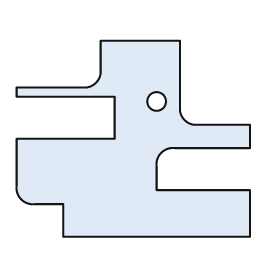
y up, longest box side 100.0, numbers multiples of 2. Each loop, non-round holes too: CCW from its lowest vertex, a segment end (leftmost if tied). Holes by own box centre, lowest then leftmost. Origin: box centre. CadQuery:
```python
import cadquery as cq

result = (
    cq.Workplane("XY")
    .moveTo(-30.0, -42.0)
    .lineTo(50.0, -42.0)
    .lineTo(50.0, -22.0)
    .lineTo(10.0, -22.0)
    .lineTo(10.0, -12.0)
    .threePointArc((12.0, -6.0), (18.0, -4.0))
    .lineTo(50.0, -4.0)
    .lineTo(50.0, 6.0)
    .lineTo(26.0, 6.0)
    .threePointArc((22.0, 8.0), (20.0, 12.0))
    .lineTo(20.0, 42.0)
    .lineTo(-14.0, 42.0)
    .lineTo(-14.0, 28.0)
    .threePointArc((-16.0, 24.0), (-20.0, 22.0))
    .lineTo(-50.0, 22.0)
    .lineTo(-50.0, 18.0)
    .lineTo(-8.0, 18.0)
    .lineTo(-8.0, 0.0)
    .lineTo(-50.0, 0.0)
    .lineTo(-50.0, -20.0)
    .threePointArc((-48.0, -26.0), (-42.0, -28.0))
    .lineTo(-30.0, -28.0)
    .close()
    .moveTo(10.0, 16.0)
    .circle(4.0)
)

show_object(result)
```